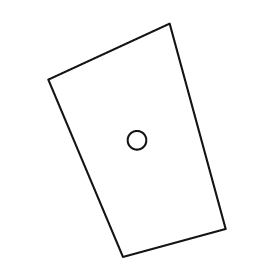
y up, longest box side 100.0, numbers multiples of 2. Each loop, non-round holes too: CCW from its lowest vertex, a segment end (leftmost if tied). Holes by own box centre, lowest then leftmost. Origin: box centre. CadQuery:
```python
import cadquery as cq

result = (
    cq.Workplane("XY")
    .moveTo(-6.0, -50.0)
    .lineTo(38.0, -38.0)
    .lineTo(14.0, 50.0)
    .lineTo(-38.0, 26.0)
    .close()
    .moveTo(0.0, 0.0)
    .circle(4.0)
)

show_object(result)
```